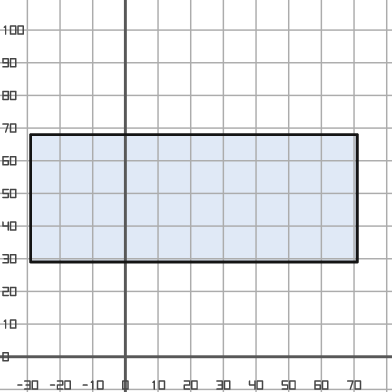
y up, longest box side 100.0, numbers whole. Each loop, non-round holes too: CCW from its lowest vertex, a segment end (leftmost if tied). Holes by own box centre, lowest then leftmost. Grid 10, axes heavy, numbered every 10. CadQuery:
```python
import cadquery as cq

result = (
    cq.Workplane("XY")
    .moveTo(-29.0, 29.0)
    .lineTo(71.0, 29.0)
    .lineTo(71.0, 68.0)
    .lineTo(-29.0, 68.0)
    .close()
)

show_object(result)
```